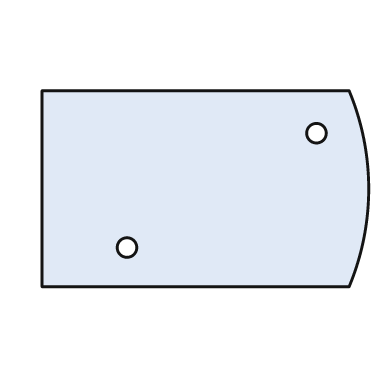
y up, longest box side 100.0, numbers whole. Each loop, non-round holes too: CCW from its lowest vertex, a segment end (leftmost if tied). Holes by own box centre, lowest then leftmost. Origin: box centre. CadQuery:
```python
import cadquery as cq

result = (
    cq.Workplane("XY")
    .moveTo(-50.0, -30.0)
    .lineTo(44.0, -30.0)
    .threePointArc((50.0, 0.0), (44.0, 30.0))
    .lineTo(-50.0, 30.0)
    .close()
    .moveTo(-24.0, -18.0)
    .circle(3.0)
    .moveTo(34.0, 17.0)
    .circle(3.0)
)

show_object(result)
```